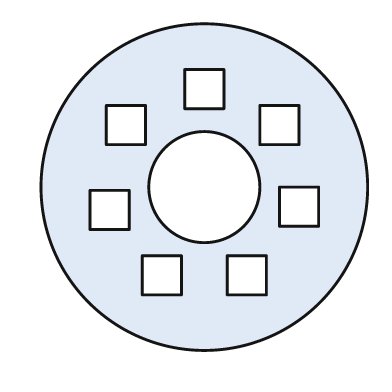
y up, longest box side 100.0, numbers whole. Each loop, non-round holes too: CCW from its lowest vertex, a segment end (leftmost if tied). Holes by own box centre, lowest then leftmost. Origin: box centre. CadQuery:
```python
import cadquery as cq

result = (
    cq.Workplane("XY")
    .moveTo(0.0, 0.0)
    .circle(50.0)
    .moveTo(-19.0, -33.0)
    .lineTo(-7.0, -33.0)
    .lineTo(-7.0, -21.0)
    .lineTo(-19.0, -21.0)
    .close()
    .moveTo(7.0, -33.0)
    .lineTo(19.0, -33.0)
    .lineTo(19.0, -21.0)
    .lineTo(7.0, -21.0)
    .close()
    .moveTo(-35.0, -13.0)
    .lineTo(-23.0, -13.0)
    .lineTo(-23.0, -1.0)
    .lineTo(-35.0, -1.0)
    .close()
    .moveTo(23.0, -12.0)
    .lineTo(35.0, -12.0)
    .lineTo(35.0, 0.0)
    .lineTo(23.0, 0.0)
    .close()
    .moveTo(0.0, 0.0)
    .circle(17.0)
    .moveTo(-30.0, 13.0)
    .lineTo(-18.0, 13.0)
    .lineTo(-18.0, 25.0)
    .lineTo(-30.0, 25.0)
    .close()
    .moveTo(17.0, 13.0)
    .lineTo(29.0, 13.0)
    .lineTo(29.0, 25.0)
    .lineTo(17.0, 25.0)
    .close()
    .moveTo(-6.0, 24.0)
    .lineTo(6.0, 24.0)
    .lineTo(6.0, 36.0)
    .lineTo(-6.0, 36.0)
    .close()
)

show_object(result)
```